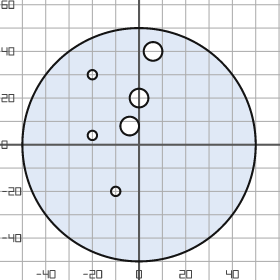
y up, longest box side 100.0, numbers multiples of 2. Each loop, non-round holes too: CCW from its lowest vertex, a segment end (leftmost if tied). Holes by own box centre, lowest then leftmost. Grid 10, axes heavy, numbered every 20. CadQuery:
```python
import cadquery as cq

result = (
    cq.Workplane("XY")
    .moveTo(0.0, 0.0)
    .circle(50.0)
    .moveTo(-10.0, -20.0)
    .circle(2.0)
    .moveTo(-20.0, 4.0)
    .circle(2.0)
    .moveTo(-4.0, 8.0)
    .circle(4.0)
    .moveTo(0.0, 20.0)
    .circle(4.0)
    .moveTo(-20.0, 30.0)
    .circle(2.0)
    .moveTo(6.0, 40.0)
    .circle(4.0)
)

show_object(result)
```